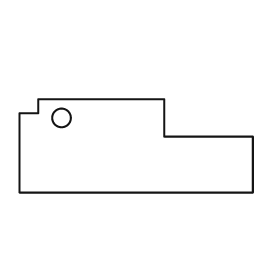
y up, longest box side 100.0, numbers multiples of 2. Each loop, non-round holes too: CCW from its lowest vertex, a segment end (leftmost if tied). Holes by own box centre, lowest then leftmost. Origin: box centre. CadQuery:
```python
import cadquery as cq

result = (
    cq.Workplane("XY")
    .moveTo(-50.0, -20.0)
    .lineTo(50.0, -20.0)
    .lineTo(50.0, 4.0)
    .lineTo(12.0, 4.0)
    .lineTo(12.0, 20.0)
    .lineTo(-42.0, 20.0)
    .lineTo(-42.0, 14.0)
    .lineTo(-50.0, 14.0)
    .close()
    .moveTo(-32.0, 12.0)
    .circle(4.0)
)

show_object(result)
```